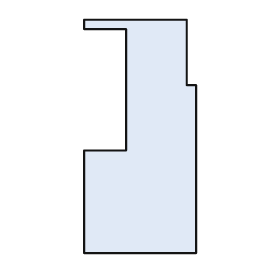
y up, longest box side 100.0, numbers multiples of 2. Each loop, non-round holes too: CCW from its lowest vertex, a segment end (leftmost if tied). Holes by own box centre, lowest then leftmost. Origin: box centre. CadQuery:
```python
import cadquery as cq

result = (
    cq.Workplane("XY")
    .moveTo(-24.0, -50.0)
    .lineTo(24.0, -50.0)
    .lineTo(24.0, 22.0)
    .lineTo(20.0, 22.0)
    .lineTo(20.0, 50.0)
    .lineTo(-24.0, 50.0)
    .lineTo(-24.0, 46.0)
    .lineTo(-6.0, 46.0)
    .lineTo(-6.0, -6.0)
    .lineTo(-24.0, -6.0)
    .close()
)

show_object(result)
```